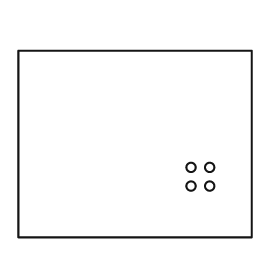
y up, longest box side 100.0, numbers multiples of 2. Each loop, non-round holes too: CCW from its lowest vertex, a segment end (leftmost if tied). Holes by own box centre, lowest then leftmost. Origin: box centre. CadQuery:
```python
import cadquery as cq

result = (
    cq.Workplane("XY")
    .moveTo(-50.0, -40.0)
    .lineTo(50.0, -40.0)
    .lineTo(50.0, 40.0)
    .lineTo(-50.0, 40.0)
    .close()
    .moveTo(24.0, -18.0)
    .circle(2.0)
    .moveTo(32.0, -18.0)
    .circle(2.0)
    .moveTo(24.0, -10.0)
    .circle(2.0)
    .moveTo(32.0, -10.0)
    .circle(2.0)
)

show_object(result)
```